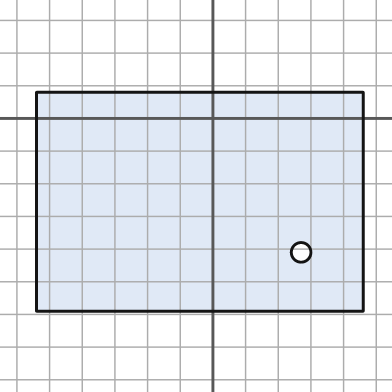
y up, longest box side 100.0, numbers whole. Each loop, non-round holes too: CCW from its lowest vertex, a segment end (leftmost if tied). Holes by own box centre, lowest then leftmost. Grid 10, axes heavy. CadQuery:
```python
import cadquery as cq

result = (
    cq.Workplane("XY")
    .moveTo(-54.0, -59.0)
    .lineTo(46.0, -59.0)
    .lineTo(46.0, 8.0)
    .lineTo(-54.0, 8.0)
    .close()
    .moveTo(27.0, -41.0)
    .circle(3.0)
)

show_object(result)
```